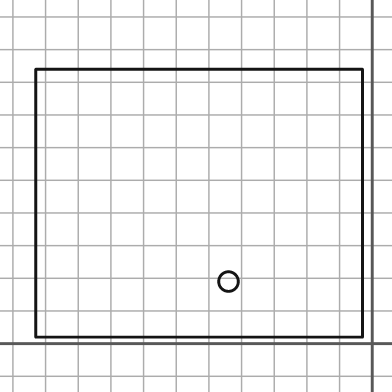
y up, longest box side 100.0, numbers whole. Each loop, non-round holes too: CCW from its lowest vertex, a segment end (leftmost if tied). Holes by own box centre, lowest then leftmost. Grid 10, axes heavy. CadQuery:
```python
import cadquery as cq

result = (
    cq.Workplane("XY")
    .moveTo(-103.0, 2.0)
    .lineTo(-3.0, 2.0)
    .lineTo(-3.0, 84.0)
    .lineTo(-103.0, 84.0)
    .close()
    .moveTo(-44.0, 19.0)
    .circle(3.0)
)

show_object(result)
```